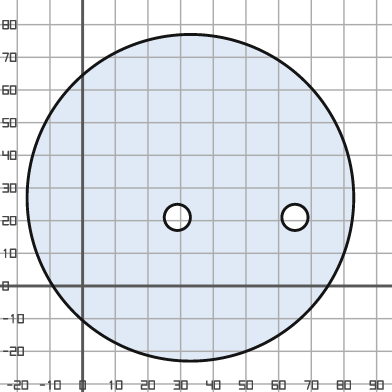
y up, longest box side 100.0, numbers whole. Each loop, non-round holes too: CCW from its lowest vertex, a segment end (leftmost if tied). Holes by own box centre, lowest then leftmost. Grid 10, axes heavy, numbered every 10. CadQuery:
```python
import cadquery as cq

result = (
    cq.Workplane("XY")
    .moveTo(33.0, 27.0)
    .circle(50.0)
    .moveTo(29.0, 21.0)
    .circle(4.0)
    .moveTo(65.0, 21.0)
    .circle(4.0)
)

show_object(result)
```